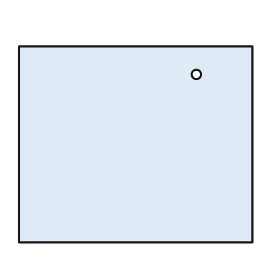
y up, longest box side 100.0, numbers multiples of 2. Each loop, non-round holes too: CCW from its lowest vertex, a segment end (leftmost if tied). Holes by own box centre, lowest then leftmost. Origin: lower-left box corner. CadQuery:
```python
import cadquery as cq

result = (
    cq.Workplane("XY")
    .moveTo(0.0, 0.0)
    .lineTo(100.0, 0.0)
    .lineTo(100.0, 84.0)
    .lineTo(0.0, 84.0)
    .close()
    .moveTo(76.0, 72.0)
    .circle(2.0)
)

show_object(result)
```